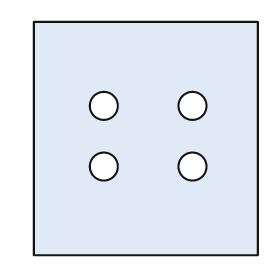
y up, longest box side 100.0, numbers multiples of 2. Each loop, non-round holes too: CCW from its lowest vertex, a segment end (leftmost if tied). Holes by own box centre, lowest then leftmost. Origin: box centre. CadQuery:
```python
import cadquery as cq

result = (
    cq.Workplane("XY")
    .moveTo(-48.0, -50.0)
    .lineTo(48.0, -50.0)
    .lineTo(48.0, 50.0)
    .lineTo(-48.0, 50.0)
    .close()
    .moveTo(-18.0, -12.0)
    .circle(6.0)
    .moveTo(20.0, -12.0)
    .circle(6.0)
    .moveTo(-18.0, 14.0)
    .circle(6.0)
    .moveTo(20.0, 14.0)
    .circle(6.0)
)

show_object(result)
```